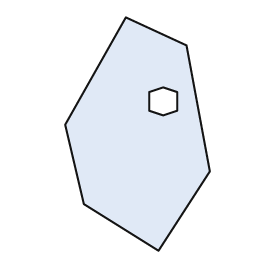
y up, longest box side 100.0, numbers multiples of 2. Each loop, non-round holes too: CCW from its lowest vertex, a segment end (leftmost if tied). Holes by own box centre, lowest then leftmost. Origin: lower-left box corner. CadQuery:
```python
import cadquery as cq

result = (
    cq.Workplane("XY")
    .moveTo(40.0, 0.0)
    .lineTo(62.0, 34.0)
    .lineTo(52.0, 88.0)
    .lineTo(26.0, 100.0)
    .lineTo(0.0, 54.0)
    .lineTo(8.0, 20.0)
    .close()
    .moveTo(42.0, 58.0)
    .lineTo(48.0, 60.0)
    .lineTo(48.0, 68.0)
    .lineTo(42.0, 70.0)
    .lineTo(36.0, 68.0)
    .lineTo(36.0, 60.0)
    .close()
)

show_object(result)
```